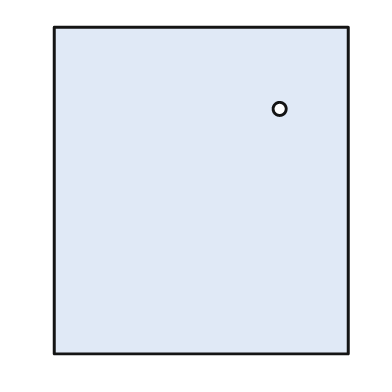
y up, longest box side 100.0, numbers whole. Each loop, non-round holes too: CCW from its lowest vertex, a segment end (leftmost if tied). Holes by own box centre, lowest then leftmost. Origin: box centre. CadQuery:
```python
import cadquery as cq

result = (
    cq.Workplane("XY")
    .moveTo(-45.0, -50.0)
    .lineTo(45.0, -50.0)
    .lineTo(45.0, 50.0)
    .lineTo(-45.0, 50.0)
    .close()
    .moveTo(24.0, 25.0)
    .circle(2.0)
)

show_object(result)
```